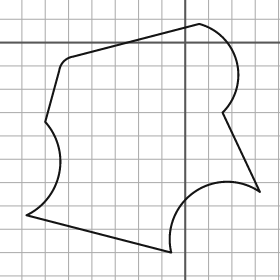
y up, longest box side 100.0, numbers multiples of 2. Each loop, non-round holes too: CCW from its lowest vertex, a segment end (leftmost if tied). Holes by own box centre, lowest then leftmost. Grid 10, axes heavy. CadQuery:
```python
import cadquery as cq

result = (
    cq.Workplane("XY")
    .moveTo(-6.0, -90.0)
    .threePointArc((4.0, -64.0), (32.0, -64.0))
    .lineTo(16.0, -30.0)
    .threePointArc((22.0, -8.0), (6.0, 8.0))
    .lineTo(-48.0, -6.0)
    .threePointArc((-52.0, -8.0), (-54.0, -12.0))
    .lineTo(-60.0, -34.0)
    .threePointArc((-54.0, -56.0), (-68.0, -74.0))
    .close()
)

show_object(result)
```